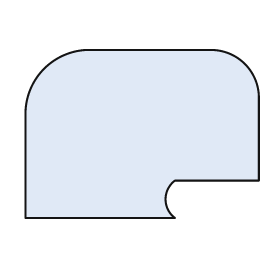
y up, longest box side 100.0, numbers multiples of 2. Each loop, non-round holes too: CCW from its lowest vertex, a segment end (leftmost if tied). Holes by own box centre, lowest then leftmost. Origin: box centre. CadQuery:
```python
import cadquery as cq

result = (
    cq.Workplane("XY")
    .moveTo(-50.0, -36.0)
    .lineTo(14.0, -36.0)
    .threePointArc((10.0, -28.0), (14.0, -20.0))
    .lineTo(50.0, -20.0)
    .lineTo(50.0, 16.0)
    .threePointArc((44.0, 30.0), (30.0, 36.0))
    .lineTo(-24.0, 36.0)
    .threePointArc((-42.0, 28.0), (-50.0, 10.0))
    .close()
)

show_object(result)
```